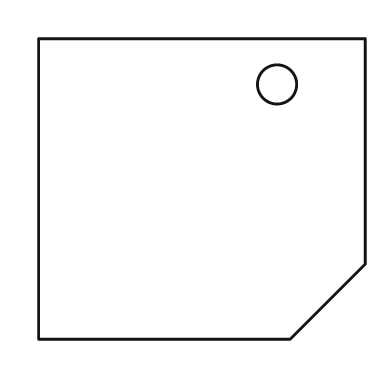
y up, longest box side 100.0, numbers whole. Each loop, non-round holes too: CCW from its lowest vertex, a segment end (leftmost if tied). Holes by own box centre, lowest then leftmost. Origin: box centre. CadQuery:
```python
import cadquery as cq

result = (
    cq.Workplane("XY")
    .moveTo(-50.0, -46.0)
    .lineTo(27.0, -46.0)
    .lineTo(50.0, -23.0)
    .lineTo(50.0, 46.0)
    .lineTo(-50.0, 46.0)
    .close()
    .moveTo(23.0, 32.0)
    .circle(6.0)
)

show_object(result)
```